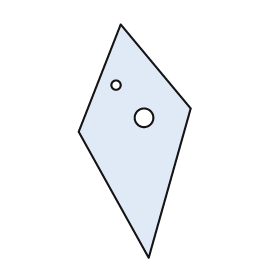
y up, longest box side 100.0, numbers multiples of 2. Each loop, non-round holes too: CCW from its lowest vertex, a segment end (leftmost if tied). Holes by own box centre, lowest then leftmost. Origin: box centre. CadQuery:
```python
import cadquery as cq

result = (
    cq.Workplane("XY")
    .moveTo(6.0, -50.0)
    .lineTo(24.0, 14.0)
    .lineTo(-6.0, 50.0)
    .lineTo(-24.0, 4.0)
    .close()
    .moveTo(4.0, 10.0)
    .circle(4.0)
    .moveTo(-8.0, 24.0)
    .circle(2.0)
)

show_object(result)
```